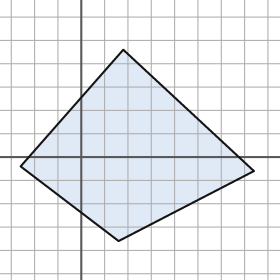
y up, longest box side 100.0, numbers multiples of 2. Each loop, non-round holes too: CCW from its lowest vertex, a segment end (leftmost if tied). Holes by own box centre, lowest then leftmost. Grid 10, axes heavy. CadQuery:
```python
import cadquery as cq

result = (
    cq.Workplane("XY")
    .moveTo(16.0, -36.0)
    .lineTo(74.0, -6.0)
    .lineTo(18.0, 46.0)
    .lineTo(-26.0, -4.0)
    .close()
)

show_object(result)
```